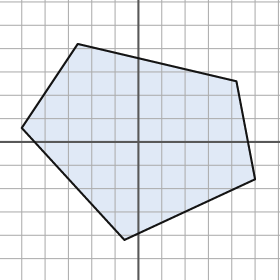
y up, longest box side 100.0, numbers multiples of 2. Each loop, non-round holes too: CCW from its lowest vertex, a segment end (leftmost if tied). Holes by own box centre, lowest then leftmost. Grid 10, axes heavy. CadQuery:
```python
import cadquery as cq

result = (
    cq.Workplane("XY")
    .moveTo(-6.0, -42.0)
    .lineTo(50.0, -16.0)
    .lineTo(42.0, 26.0)
    .lineTo(-26.0, 42.0)
    .lineTo(-50.0, 6.0)
    .close()
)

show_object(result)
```